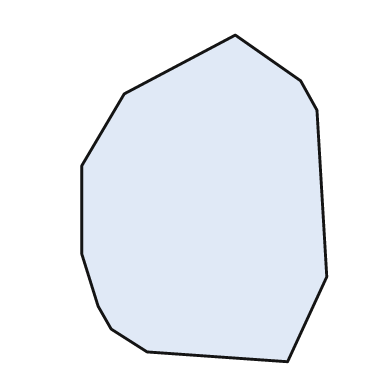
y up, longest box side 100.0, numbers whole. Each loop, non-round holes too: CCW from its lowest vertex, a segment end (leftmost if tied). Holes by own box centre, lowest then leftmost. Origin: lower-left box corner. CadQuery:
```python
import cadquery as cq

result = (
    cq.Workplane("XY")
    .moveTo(63.0, 0.0)
    .lineTo(75.0, 26.0)
    .lineTo(72.0, 77.0)
    .lineTo(67.0, 86.0)
    .lineTo(47.0, 100.0)
    .lineTo(13.0, 82.0)
    .lineTo(0.0, 60.0)
    .lineTo(0.0, 33.0)
    .lineTo(5.0, 17.0)
    .lineTo(9.0, 10.0)
    .lineTo(20.0, 3.0)
    .close()
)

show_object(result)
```